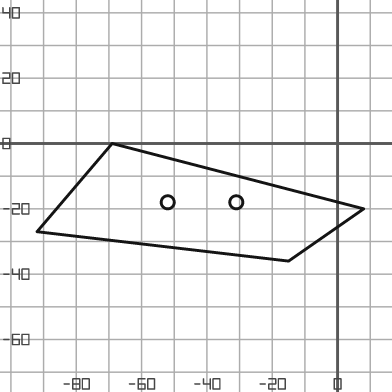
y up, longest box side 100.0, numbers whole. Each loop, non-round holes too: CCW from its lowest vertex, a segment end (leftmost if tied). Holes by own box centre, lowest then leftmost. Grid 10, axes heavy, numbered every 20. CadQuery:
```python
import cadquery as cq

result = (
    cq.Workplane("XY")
    .moveTo(-15.0, -36.0)
    .lineTo(8.0, -20.0)
    .lineTo(-69.0, 0.0)
    .lineTo(-92.0, -27.0)
    .close()
    .moveTo(-52.0, -18.0)
    .circle(2.0)
    .moveTo(-31.0, -18.0)
    .circle(2.0)
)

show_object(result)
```